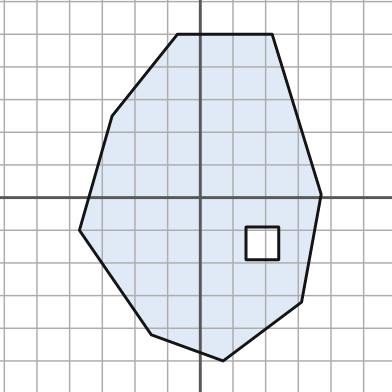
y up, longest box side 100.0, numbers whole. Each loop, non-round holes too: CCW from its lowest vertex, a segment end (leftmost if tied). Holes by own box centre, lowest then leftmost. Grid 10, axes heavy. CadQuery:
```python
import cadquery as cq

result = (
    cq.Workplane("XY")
    .moveTo(7.0, -50.0)
    .lineTo(31.0, -32.0)
    .lineTo(37.0, 1.0)
    .lineTo(22.0, 50.0)
    .lineTo(-7.0, 50.0)
    .lineTo(-27.0, 25.0)
    .lineTo(-37.0, -10.0)
    .lineTo(-15.0, -42.0)
    .close()
    .moveTo(14.0, -19.0)
    .lineTo(24.0, -19.0)
    .lineTo(24.0, -9.0)
    .lineTo(14.0, -9.0)
    .close()
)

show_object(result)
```